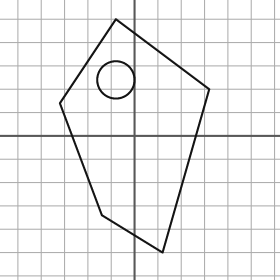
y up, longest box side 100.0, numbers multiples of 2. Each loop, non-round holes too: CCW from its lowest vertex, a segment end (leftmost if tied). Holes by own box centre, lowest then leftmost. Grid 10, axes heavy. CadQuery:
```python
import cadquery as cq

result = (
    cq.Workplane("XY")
    .moveTo(12.0, -50.0)
    .lineTo(32.0, 20.0)
    .lineTo(-8.0, 50.0)
    .lineTo(-32.0, 14.0)
    .lineTo(-14.0, -34.0)
    .close()
    .moveTo(-8.0, 24.0)
    .circle(8.0)
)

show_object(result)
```